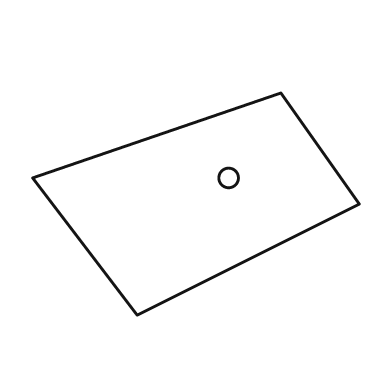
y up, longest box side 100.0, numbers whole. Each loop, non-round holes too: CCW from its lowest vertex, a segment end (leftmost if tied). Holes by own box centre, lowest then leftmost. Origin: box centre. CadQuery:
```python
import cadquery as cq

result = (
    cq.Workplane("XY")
    .moveTo(-18.0, -34.0)
    .lineTo(50.0, 0.0)
    .lineTo(26.0, 34.0)
    .lineTo(-50.0, 8.0)
    .close()
    .moveTo(10.0, 8.0)
    .circle(3.0)
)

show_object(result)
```